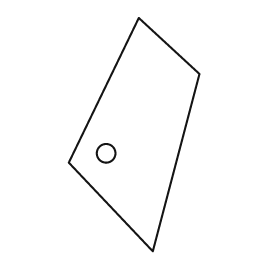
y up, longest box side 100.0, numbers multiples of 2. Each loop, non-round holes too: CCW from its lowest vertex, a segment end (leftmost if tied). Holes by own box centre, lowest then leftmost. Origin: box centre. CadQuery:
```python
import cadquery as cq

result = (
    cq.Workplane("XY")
    .moveTo(8.0, -50.0)
    .lineTo(28.0, 26.0)
    .lineTo(2.0, 50.0)
    .lineTo(-28.0, -12.0)
    .close()
    .moveTo(-12.0, -8.0)
    .circle(4.0)
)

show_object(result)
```